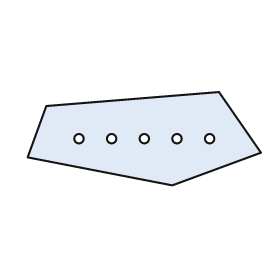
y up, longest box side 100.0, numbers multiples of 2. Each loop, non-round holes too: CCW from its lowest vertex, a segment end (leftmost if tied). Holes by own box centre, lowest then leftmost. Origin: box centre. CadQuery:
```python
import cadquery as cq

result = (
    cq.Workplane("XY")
    .moveTo(12.0, -20.0)
    .lineTo(50.0, -6.0)
    .lineTo(32.0, 20.0)
    .lineTo(-42.0, 14.0)
    .lineTo(-50.0, -8.0)
    .close()
    .moveTo(-28.0, 0.0)
    .circle(2.0)
    .moveTo(-14.0, 0.0)
    .circle(2.0)
    .moveTo(0.0, 0.0)
    .circle(2.0)
    .moveTo(14.0, 0.0)
    .circle(2.0)
    .moveTo(28.0, 0.0)
    .circle(2.0)
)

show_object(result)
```